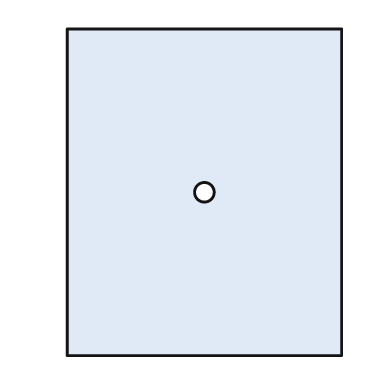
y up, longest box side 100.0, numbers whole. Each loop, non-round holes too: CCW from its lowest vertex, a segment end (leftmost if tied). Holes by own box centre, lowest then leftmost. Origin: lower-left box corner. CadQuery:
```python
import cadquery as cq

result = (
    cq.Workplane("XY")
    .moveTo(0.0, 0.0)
    .lineTo(84.0, 0.0)
    .lineTo(84.0, 100.0)
    .lineTo(0.0, 100.0)
    .close()
    .moveTo(42.0, 50.0)
    .circle(3.0)
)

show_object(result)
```